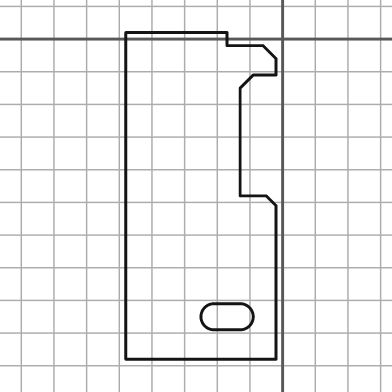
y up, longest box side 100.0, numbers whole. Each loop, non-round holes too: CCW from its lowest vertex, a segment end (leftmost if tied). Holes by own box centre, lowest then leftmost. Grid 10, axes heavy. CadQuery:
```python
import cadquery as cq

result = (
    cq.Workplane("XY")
    .moveTo(-48.0, -98.0)
    .lineTo(-2.0, -98.0)
    .lineTo(-2.0, -51.0)
    .lineTo(-5.0, -48.0)
    .lineTo(-13.0, -48.0)
    .lineTo(-13.0, -15.0)
    .lineTo(-9.0, -11.0)
    .lineTo(-2.0, -11.0)
    .lineTo(-2.0, -6.0)
    .lineTo(-6.0, -2.0)
    .lineTo(-17.0, -2.0)
    .lineTo(-17.0, 2.0)
    .lineTo(-48.0, 2.0)
    .close()
    .moveTo(-21.0, -89.0)
    .lineTo(-13.0, -89.0)
    .threePointArc((-9.0, -85.0), (-13.0, -81.0))
    .lineTo(-21.0, -81.0)
    .threePointArc((-25.0, -85.0), (-21.0, -89.0))
    .close()
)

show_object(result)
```